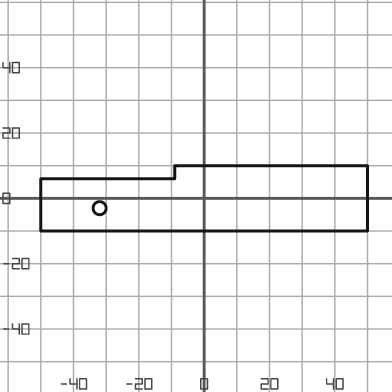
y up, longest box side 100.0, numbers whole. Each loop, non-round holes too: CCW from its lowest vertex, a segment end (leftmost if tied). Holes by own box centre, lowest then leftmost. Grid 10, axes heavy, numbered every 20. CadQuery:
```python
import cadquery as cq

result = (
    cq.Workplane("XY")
    .moveTo(-50.0, -10.0)
    .lineTo(50.0, -10.0)
    .lineTo(50.0, 10.0)
    .lineTo(-9.0, 10.0)
    .lineTo(-9.0, 6.0)
    .lineTo(-50.0, 6.0)
    .close()
    .moveTo(-32.0, -3.0)
    .circle(2.0)
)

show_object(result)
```